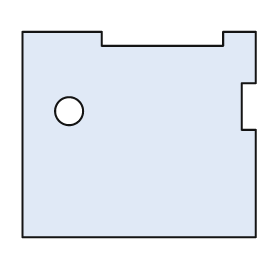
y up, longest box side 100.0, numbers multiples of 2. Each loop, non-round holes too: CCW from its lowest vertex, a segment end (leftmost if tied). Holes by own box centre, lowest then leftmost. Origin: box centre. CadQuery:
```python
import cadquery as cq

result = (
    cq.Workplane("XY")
    .moveTo(-50.0, -44.0)
    .lineTo(50.0, -44.0)
    .lineTo(50.0, 2.0)
    .lineTo(44.0, 2.0)
    .lineTo(44.0, 22.0)
    .lineTo(50.0, 22.0)
    .lineTo(50.0, 44.0)
    .lineTo(36.0, 44.0)
    .lineTo(36.0, 38.0)
    .lineTo(-16.0, 38.0)
    .lineTo(-16.0, 44.0)
    .lineTo(-50.0, 44.0)
    .close()
    .moveTo(-30.0, 10.0)
    .circle(6.0)
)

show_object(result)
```